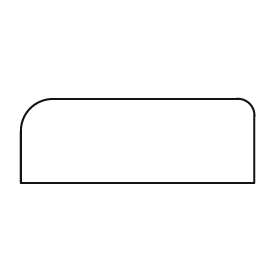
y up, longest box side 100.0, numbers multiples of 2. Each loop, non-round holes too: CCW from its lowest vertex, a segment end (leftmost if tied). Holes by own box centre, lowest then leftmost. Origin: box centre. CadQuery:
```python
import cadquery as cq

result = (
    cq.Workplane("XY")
    .moveTo(-50.0, -18.0)
    .lineTo(50.0, -18.0)
    .lineTo(50.0, 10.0)
    .threePointArc((48.0, 16.0), (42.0, 18.0))
    .lineTo(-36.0, 18.0)
    .threePointArc((-46.0, 14.0), (-50.0, 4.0))
    .close()
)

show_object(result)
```